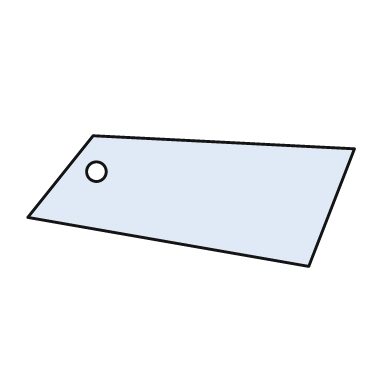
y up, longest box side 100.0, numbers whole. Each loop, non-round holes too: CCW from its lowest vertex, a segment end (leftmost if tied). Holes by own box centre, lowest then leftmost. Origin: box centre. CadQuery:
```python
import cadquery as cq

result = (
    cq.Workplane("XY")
    .moveTo(36.0, -20.0)
    .lineTo(50.0, 16.0)
    .lineTo(-30.0, 20.0)
    .lineTo(-50.0, -5.0)
    .close()
    .moveTo(-29.0, 9.0)
    .circle(3.0)
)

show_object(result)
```